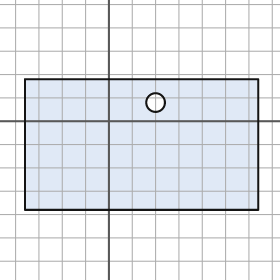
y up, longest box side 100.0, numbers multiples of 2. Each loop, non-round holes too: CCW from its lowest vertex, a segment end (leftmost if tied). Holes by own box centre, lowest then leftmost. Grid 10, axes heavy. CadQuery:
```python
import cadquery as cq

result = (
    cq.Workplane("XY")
    .moveTo(-36.0, -38.0)
    .lineTo(64.0, -38.0)
    .lineTo(64.0, 18.0)
    .lineTo(-36.0, 18.0)
    .close()
    .moveTo(20.0, 8.0)
    .circle(4.0)
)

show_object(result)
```